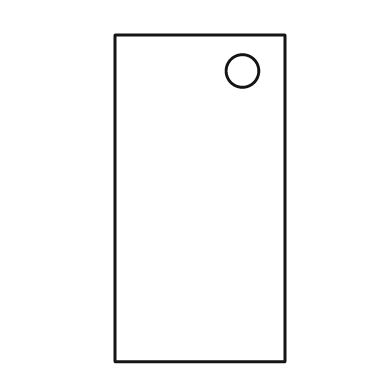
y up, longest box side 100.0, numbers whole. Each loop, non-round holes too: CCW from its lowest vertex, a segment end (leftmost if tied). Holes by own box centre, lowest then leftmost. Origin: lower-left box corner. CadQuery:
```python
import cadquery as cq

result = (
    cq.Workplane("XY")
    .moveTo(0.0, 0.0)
    .lineTo(52.0, 0.0)
    .lineTo(52.0, 100.0)
    .lineTo(0.0, 100.0)
    .close()
    .moveTo(39.0, 89.0)
    .circle(5.0)
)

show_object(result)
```